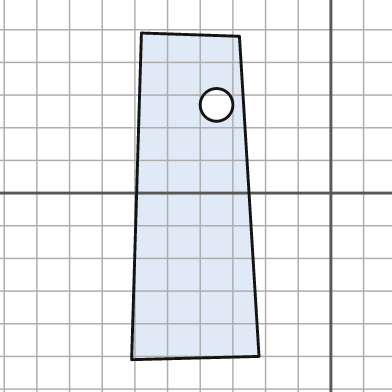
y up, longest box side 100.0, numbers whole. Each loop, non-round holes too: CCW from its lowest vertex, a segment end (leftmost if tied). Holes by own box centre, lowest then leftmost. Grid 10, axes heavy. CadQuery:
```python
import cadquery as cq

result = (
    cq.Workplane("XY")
    .moveTo(-61.0, -51.0)
    .lineTo(-22.0, -50.0)
    .lineTo(-28.0, 48.0)
    .lineTo(-58.0, 49.0)
    .close()
    .moveTo(-35.0, 27.0)
    .circle(5.0)
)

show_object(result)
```